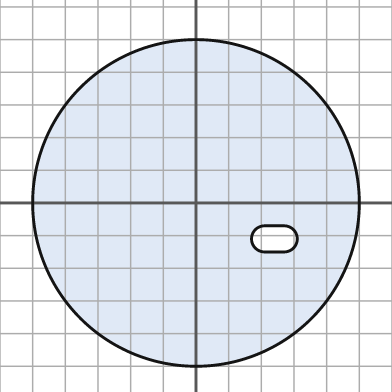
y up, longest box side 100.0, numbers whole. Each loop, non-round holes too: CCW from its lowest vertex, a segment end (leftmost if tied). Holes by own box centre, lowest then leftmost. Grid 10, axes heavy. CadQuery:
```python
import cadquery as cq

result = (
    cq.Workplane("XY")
    .moveTo(0.0, 0.0)
    .circle(50.0)
    .moveTo(21.0, -15.0)
    .lineTo(27.0, -15.0)
    .threePointArc((31.0, -11.0), (27.0, -7.0))
    .lineTo(21.0, -7.0)
    .threePointArc((17.0, -11.0), (21.0, -15.0))
    .close()
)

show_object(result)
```